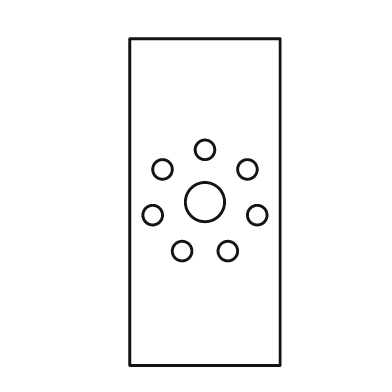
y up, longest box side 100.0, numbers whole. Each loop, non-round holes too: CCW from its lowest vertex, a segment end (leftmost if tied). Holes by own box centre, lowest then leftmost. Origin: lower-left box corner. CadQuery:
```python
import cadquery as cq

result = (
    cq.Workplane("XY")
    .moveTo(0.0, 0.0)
    .lineTo(46.0, 0.0)
    .lineTo(46.0, 100.0)
    .lineTo(0.0, 100.0)
    .close()
    .moveTo(16.0, 35.0)
    .circle(3.0)
    .moveTo(30.0, 35.0)
    .circle(3.0)
    .moveTo(7.0, 46.0)
    .circle(3.0)
    .moveTo(39.0, 46.0)
    .circle(3.0)
    .moveTo(23.0, 50.0)
    .circle(6.0)
    .moveTo(10.0, 60.0)
    .circle(3.0)
    .moveTo(36.0, 60.0)
    .circle(3.0)
    .moveTo(23.0, 66.0)
    .circle(3.0)
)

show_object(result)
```